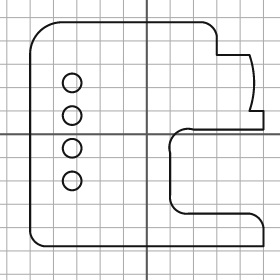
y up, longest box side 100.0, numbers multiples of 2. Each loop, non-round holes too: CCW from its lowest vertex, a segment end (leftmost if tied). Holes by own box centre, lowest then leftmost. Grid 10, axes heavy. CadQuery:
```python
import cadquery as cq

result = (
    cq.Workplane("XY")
    .moveTo(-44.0, -48.0)
    .lineTo(50.0, -48.0)
    .lineTo(50.0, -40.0)
    .threePointArc((48.0, -36.0), (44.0, -34.0))
    .lineTo(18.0, -34.0)
    .threePointArc((12.0, -32.0), (10.0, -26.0))
    .lineTo(10.0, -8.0)
    .threePointArc((12.0, 0.0), (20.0, 2.0))
    .lineTo(50.0, 2.0)
    .lineTo(50.0, 10.0)
    .lineTo(44.0, 10.0)
    .threePointArc((46.0, 22.0), (44.0, 34.0))
    .lineTo(30.0, 34.0)
    .lineTo(30.0, 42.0)
    .threePointArc((28.0, 46.0), (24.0, 48.0))
    .lineTo(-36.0, 48.0)
    .threePointArc((-46.0, 44.0), (-50.0, 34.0))
    .lineTo(-50.0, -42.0)
    .threePointArc((-48.0, -46.0), (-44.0, -48.0))
    .close()
    .moveTo(-32.0, -20.0)
    .circle(4.0)
    .moveTo(-32.0, -6.0)
    .circle(4.0)
    .moveTo(-32.0, 8.0)
    .circle(4.0)
    .moveTo(-32.0, 22.0)
    .circle(4.0)
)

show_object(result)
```